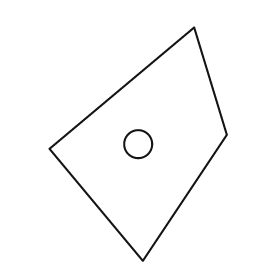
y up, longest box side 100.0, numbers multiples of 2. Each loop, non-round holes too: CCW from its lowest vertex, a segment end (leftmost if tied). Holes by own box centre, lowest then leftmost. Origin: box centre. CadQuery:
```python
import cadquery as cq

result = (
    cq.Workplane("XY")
    .moveTo(2.0, -50.0)
    .lineTo(38.0, 4.0)
    .lineTo(24.0, 50.0)
    .lineTo(-38.0, -2.0)
    .close()
    .moveTo(0.0, 0.0)
    .circle(6.0)
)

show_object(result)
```